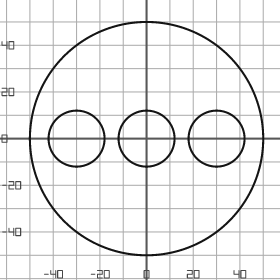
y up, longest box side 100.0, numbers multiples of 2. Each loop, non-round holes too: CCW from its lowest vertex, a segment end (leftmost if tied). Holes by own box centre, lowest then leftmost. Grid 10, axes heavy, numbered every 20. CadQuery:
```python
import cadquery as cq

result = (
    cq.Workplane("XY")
    .moveTo(0.0, 0.0)
    .circle(50.0)
    .moveTo(-30.0, 0.0)
    .circle(12.0)
    .moveTo(0.0, 0.0)
    .circle(12.0)
    .moveTo(30.0, 0.0)
    .circle(12.0)
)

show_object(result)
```